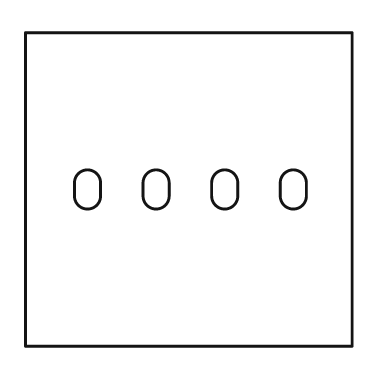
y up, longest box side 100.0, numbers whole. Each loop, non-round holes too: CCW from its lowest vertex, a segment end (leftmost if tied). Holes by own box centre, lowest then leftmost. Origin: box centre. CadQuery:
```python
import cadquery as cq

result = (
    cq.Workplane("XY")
    .moveTo(-50.0, -48.0)
    .lineTo(50.0, -48.0)
    .lineTo(50.0, 48.0)
    .lineTo(-50.0, 48.0)
    .close()
    .moveTo(-35.0, -2.0)
    .threePointArc((-31.0, -6.0), (-27.0, -2.0))
    .lineTo(-27.0, 2.0)
    .threePointArc((-31.0, 6.0), (-35.0, 2.0))
    .close()
    .moveTo(-14.0, -2.0)
    .threePointArc((-10.0, -6.0), (-6.0, -2.0))
    .lineTo(-6.0, 2.0)
    .threePointArc((-10.0, 6.0), (-14.0, 2.0))
    .close()
    .moveTo(7.0, -2.0)
    .threePointArc((11.0, -6.0), (15.0, -2.0))
    .lineTo(15.0, 2.0)
    .threePointArc((11.0, 6.0), (7.0, 2.0))
    .close()
    .moveTo(28.0, -2.0)
    .threePointArc((32.0, -6.0), (36.0, -2.0))
    .lineTo(36.0, 2.0)
    .threePointArc((32.0, 6.0), (28.0, 2.0))
    .close()
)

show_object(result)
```